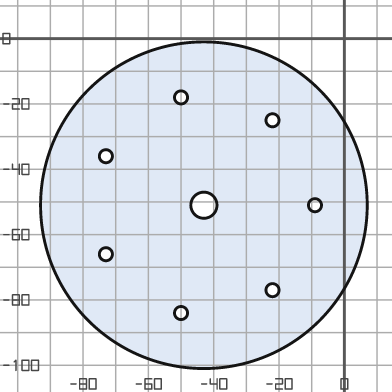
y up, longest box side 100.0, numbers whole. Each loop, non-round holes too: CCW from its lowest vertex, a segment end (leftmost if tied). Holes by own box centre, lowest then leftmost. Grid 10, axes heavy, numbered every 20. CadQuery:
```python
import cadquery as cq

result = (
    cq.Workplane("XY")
    .moveTo(-43.0, -51.0)
    .circle(50.0)
    .moveTo(-50.0, -84.0)
    .circle(2.0)
    .moveTo(-22.0, -77.0)
    .circle(2.0)
    .moveTo(-73.0, -66.0)
    .circle(2.0)
    .moveTo(-43.0, -51.0)
    .circle(4.0)
    .moveTo(-9.0, -51.0)
    .circle(2.0)
    .moveTo(-73.0, -36.0)
    .circle(2.0)
    .moveTo(-22.0, -25.0)
    .circle(2.0)
    .moveTo(-50.0, -18.0)
    .circle(2.0)
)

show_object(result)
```